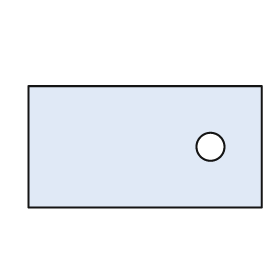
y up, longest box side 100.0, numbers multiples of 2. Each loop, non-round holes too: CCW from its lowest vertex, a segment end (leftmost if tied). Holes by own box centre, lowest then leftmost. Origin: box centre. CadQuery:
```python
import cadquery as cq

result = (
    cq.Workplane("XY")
    .moveTo(-50.0, -26.0)
    .lineTo(50.0, -26.0)
    .lineTo(50.0, 26.0)
    .lineTo(-50.0, 26.0)
    .close()
    .moveTo(28.0, 0.0)
    .circle(6.0)
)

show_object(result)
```